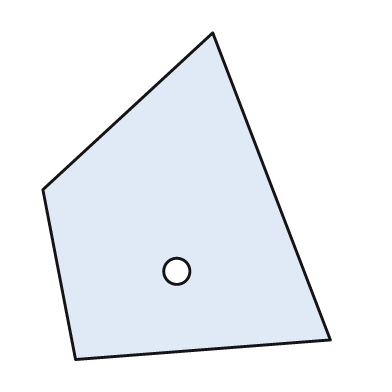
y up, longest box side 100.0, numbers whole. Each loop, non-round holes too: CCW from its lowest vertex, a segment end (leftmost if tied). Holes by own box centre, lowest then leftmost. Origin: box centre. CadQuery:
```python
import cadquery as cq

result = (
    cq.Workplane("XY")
    .moveTo(-34.0, -50.0)
    .lineTo(44.0, -44.0)
    .lineTo(8.0, 50.0)
    .lineTo(-44.0, 2.0)
    .close()
    .moveTo(-3.0, -23.0)
    .circle(4.0)
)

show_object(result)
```